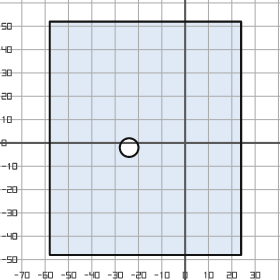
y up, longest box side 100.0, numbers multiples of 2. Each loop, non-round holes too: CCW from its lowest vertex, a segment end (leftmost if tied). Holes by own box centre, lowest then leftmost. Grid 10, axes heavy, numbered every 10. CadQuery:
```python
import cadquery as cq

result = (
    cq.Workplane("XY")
    .moveTo(-58.0, -48.0)
    .lineTo(24.0, -48.0)
    .lineTo(24.0, 52.0)
    .lineTo(-58.0, 52.0)
    .close()
    .moveTo(-24.0, -2.0)
    .circle(4.0)
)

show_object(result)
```